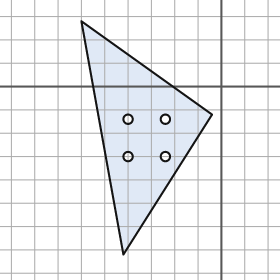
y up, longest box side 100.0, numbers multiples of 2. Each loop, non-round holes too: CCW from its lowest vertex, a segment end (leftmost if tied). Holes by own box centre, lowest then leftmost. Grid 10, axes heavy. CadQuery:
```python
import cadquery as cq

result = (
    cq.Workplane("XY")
    .moveTo(-42.0, -72.0)
    .lineTo(-4.0, -12.0)
    .lineTo(-60.0, 28.0)
    .close()
    .moveTo(-40.0, -30.0)
    .circle(2.0)
    .moveTo(-24.0, -30.0)
    .circle(2.0)
    .moveTo(-40.0, -14.0)
    .circle(2.0)
    .moveTo(-24.0, -14.0)
    .circle(2.0)
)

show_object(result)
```